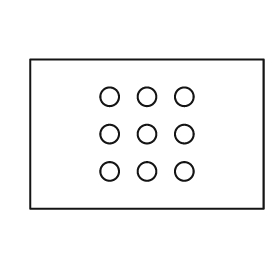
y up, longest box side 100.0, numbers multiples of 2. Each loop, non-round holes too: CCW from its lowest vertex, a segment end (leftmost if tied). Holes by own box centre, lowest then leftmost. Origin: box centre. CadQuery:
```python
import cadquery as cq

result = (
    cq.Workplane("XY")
    .moveTo(-50.0, -32.0)
    .lineTo(50.0, -32.0)
    .lineTo(50.0, 32.0)
    .lineTo(-50.0, 32.0)
    .close()
    .moveTo(-16.0, -16.0)
    .circle(4.0)
    .moveTo(0.0, -16.0)
    .circle(4.0)
    .moveTo(16.0, -16.0)
    .circle(4.0)
    .moveTo(-16.0, 0.0)
    .circle(4.0)
    .moveTo(0.0, 0.0)
    .circle(4.0)
    .moveTo(16.0, 0.0)
    .circle(4.0)
    .moveTo(-16.0, 16.0)
    .circle(4.0)
    .moveTo(0.0, 16.0)
    .circle(4.0)
    .moveTo(16.0, 16.0)
    .circle(4.0)
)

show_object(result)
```